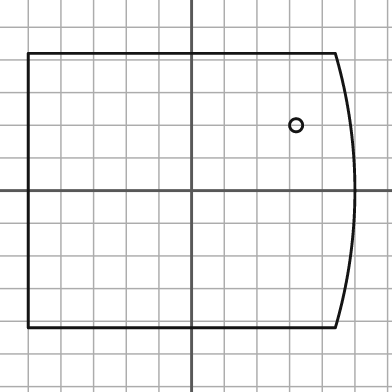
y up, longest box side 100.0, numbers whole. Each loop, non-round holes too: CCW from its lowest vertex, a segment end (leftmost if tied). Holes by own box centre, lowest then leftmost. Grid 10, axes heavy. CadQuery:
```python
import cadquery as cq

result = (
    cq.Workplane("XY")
    .moveTo(-50.0, -42.0)
    .lineTo(44.0, -42.0)
    .threePointArc((50.0, 0.0), (44.0, 42.0))
    .lineTo(-50.0, 42.0)
    .close()
    .moveTo(32.0, 20.0)
    .circle(2.0)
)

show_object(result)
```